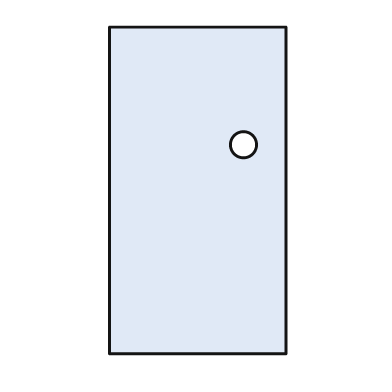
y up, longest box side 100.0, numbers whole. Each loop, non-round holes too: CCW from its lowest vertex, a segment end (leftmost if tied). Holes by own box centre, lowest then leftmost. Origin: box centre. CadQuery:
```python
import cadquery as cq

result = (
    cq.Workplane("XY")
    .moveTo(-27.0, -50.0)
    .lineTo(27.0, -50.0)
    .lineTo(27.0, 50.0)
    .lineTo(-27.0, 50.0)
    .close()
    .moveTo(14.0, 14.0)
    .circle(4.0)
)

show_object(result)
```